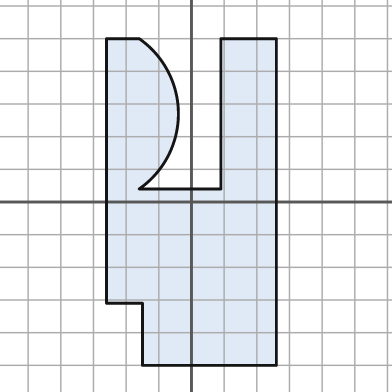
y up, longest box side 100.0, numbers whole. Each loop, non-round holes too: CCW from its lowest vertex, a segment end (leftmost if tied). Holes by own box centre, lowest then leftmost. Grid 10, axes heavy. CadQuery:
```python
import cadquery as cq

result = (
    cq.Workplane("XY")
    .moveTo(-15.0, -50.0)
    .lineTo(26.0, -50.0)
    .lineTo(26.0, 50.0)
    .lineTo(9.0, 50.0)
    .lineTo(9.0, 4.0)
    .lineTo(-16.0, 4.0)
    .threePointArc((-4.0, 27.0), (-16.0, 50.0))
    .lineTo(-26.0, 50.0)
    .lineTo(-26.0, -31.0)
    .lineTo(-15.0, -31.0)
    .close()
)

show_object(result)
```